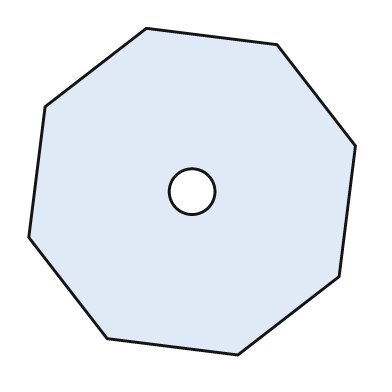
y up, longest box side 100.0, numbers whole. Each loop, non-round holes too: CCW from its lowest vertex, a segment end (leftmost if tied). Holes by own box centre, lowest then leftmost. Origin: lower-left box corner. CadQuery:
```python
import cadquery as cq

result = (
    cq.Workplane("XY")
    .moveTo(64.0, 0.0)
    .lineTo(95.0, 24.0)
    .lineTo(100.0, 64.0)
    .lineTo(76.0, 95.0)
    .lineTo(36.0, 100.0)
    .lineTo(5.0, 76.0)
    .lineTo(0.0, 36.0)
    .lineTo(24.0, 5.0)
    .close()
    .moveTo(50.0, 50.0)
    .circle(7.0)
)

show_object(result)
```